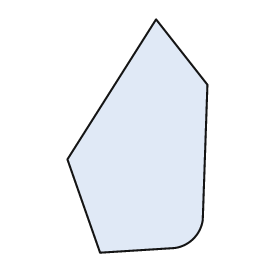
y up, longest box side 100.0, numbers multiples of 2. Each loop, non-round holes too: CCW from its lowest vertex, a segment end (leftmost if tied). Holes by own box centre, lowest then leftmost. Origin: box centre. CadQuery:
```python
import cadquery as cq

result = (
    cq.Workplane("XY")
    .moveTo(-16.0, -50.0)
    .lineTo(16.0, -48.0)
    .threePointArc((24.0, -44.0), (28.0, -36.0))
    .lineTo(30.0, 22.0)
    .lineTo(8.0, 50.0)
    .lineTo(-30.0, -10.0)
    .close()
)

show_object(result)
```